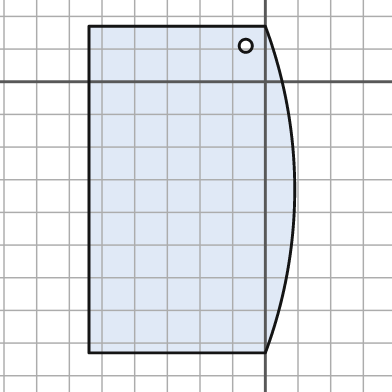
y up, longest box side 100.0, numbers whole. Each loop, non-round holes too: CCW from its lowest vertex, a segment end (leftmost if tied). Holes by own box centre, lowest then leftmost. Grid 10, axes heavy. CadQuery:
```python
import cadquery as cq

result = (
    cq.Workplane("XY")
    .moveTo(-54.0, -83.0)
    .lineTo(0.0, -83.0)
    .threePointArc((9.0, -33.0), (0.0, 17.0))
    .lineTo(-54.0, 17.0)
    .close()
    .moveTo(-6.0, 11.0)
    .circle(2.0)
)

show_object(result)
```